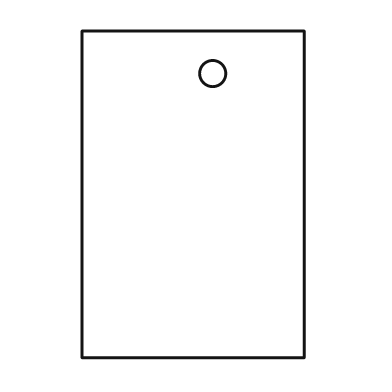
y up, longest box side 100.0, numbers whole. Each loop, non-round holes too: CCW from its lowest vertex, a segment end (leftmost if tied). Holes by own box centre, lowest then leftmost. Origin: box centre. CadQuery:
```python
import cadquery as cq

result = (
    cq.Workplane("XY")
    .moveTo(-34.0, -50.0)
    .lineTo(34.0, -50.0)
    .lineTo(34.0, 50.0)
    .lineTo(-34.0, 50.0)
    .close()
    .moveTo(6.0, 37.0)
    .circle(4.0)
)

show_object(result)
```